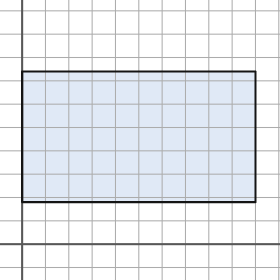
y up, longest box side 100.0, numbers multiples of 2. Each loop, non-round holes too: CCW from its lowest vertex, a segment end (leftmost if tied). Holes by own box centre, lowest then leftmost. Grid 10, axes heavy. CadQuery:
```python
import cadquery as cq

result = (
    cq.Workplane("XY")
    .moveTo(0.0, 18.0)
    .lineTo(100.0, 18.0)
    .lineTo(100.0, 74.0)
    .lineTo(0.0, 74.0)
    .close()
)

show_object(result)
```